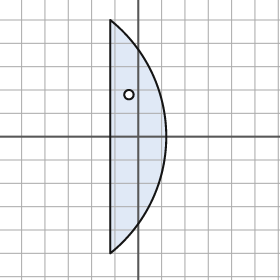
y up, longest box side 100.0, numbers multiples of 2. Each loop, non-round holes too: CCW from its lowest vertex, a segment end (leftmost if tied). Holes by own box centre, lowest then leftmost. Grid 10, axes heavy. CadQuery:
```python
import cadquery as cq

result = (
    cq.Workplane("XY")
    .moveTo(-12.0, -50.0)
    .threePointArc((12.0, 0.0), (-12.0, 50.0))
    .close()
    .moveTo(-4.0, 18.0)
    .circle(2.0)
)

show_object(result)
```